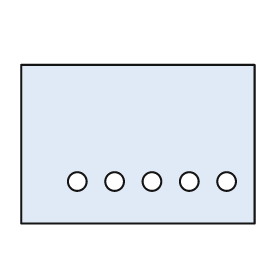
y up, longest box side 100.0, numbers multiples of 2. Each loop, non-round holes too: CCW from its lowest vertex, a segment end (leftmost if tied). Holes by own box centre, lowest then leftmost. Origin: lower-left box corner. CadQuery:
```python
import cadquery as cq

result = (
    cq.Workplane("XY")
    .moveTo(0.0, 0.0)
    .lineTo(100.0, 0.0)
    .lineTo(100.0, 68.0)
    .lineTo(0.0, 68.0)
    .close()
    .moveTo(24.0, 18.0)
    .circle(4.0)
    .moveTo(40.0, 18.0)
    .circle(4.0)
    .moveTo(56.0, 18.0)
    .circle(4.0)
    .moveTo(72.0, 18.0)
    .circle(4.0)
    .moveTo(88.0, 18.0)
    .circle(4.0)
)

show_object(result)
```